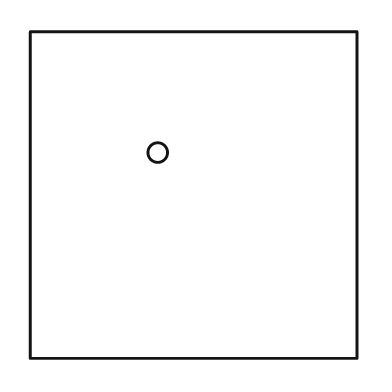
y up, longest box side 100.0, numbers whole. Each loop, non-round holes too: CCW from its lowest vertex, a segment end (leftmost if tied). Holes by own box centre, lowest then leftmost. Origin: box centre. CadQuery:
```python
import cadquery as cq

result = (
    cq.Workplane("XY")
    .moveTo(-50.0, -50.0)
    .lineTo(50.0, -50.0)
    .lineTo(50.0, 50.0)
    .lineTo(-50.0, 50.0)
    .close()
    .moveTo(-11.0, 13.0)
    .circle(3.0)
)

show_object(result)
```